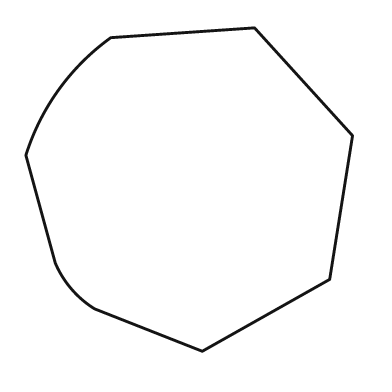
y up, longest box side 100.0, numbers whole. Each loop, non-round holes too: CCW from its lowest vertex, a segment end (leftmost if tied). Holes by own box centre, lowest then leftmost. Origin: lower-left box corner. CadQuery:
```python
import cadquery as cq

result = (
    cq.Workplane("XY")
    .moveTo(54.0, 0.0)
    .lineTo(93.0, 22.0)
    .lineTo(100.0, 66.0)
    .lineTo(70.0, 99.0)
    .lineTo(26.0, 96.0)
    .threePointArc((10.0, 80.0), (0.0, 60.0))
    .lineTo(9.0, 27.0)
    .threePointArc((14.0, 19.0), (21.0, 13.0))
    .close()
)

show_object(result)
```